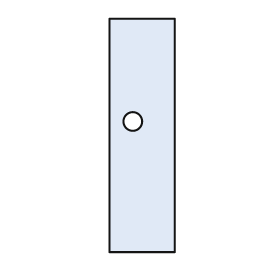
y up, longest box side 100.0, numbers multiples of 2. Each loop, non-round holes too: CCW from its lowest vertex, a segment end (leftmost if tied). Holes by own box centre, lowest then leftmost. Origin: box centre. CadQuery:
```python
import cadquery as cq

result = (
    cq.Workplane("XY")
    .moveTo(-14.0, -50.0)
    .lineTo(14.0, -50.0)
    .lineTo(14.0, 50.0)
    .lineTo(-14.0, 50.0)
    .close()
    .moveTo(-4.0, 6.0)
    .circle(4.0)
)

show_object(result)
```